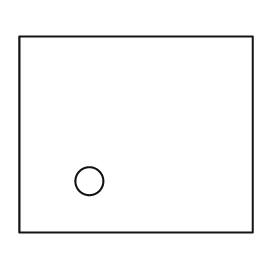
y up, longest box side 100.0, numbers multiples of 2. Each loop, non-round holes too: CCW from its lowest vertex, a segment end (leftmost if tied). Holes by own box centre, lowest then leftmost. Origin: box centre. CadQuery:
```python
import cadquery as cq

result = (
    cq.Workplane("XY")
    .moveTo(-50.0, -42.0)
    .lineTo(50.0, -42.0)
    .lineTo(50.0, 42.0)
    .lineTo(-50.0, 42.0)
    .close()
    .moveTo(-20.0, -20.0)
    .circle(6.0)
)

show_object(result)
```